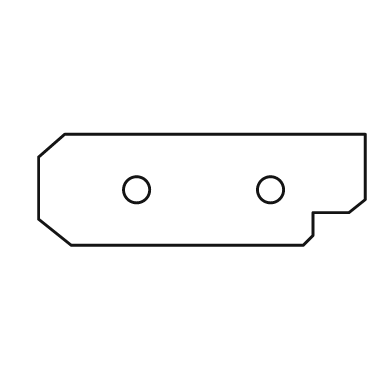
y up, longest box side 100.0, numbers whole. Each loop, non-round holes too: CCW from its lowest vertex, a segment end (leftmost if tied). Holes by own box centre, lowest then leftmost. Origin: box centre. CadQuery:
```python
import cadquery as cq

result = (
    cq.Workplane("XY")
    .moveTo(-40.0, -17.0)
    .lineTo(31.0, -17.0)
    .lineTo(34.0, -14.0)
    .lineTo(34.0, -7.0)
    .lineTo(45.0, -7.0)
    .lineTo(50.0, -3.0)
    .lineTo(50.0, 17.0)
    .lineTo(-42.0, 17.0)
    .lineTo(-50.0, 10.0)
    .lineTo(-50.0, -9.0)
    .close()
    .moveTo(-20.0, 0.0)
    .circle(4.0)
    .moveTo(21.0, 0.0)
    .circle(4.0)
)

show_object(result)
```